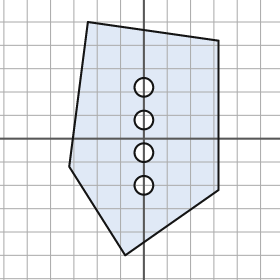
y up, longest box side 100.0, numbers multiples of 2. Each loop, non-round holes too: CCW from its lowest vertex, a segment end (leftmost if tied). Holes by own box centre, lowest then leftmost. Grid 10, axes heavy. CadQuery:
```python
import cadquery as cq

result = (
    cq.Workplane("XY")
    .moveTo(-8.0, -50.0)
    .lineTo(32.0, -22.0)
    .lineTo(32.0, 42.0)
    .lineTo(-24.0, 50.0)
    .lineTo(-32.0, -12.0)
    .close()
    .moveTo(0.0, -20.0)
    .circle(4.0)
    .moveTo(0.0, -6.0)
    .circle(4.0)
    .moveTo(0.0, 8.0)
    .circle(4.0)
    .moveTo(0.0, 22.0)
    .circle(4.0)
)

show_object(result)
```